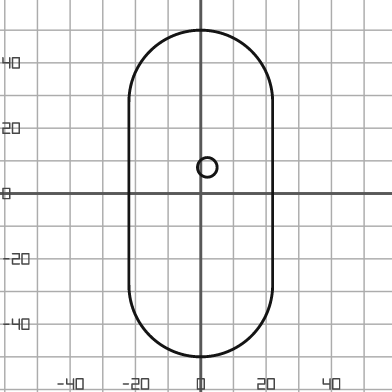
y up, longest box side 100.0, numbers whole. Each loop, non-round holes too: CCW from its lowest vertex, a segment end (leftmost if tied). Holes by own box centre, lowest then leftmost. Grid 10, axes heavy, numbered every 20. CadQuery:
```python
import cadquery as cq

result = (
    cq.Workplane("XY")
    .moveTo(-22.0, -28.0)
    .threePointArc((0.0, -50.0), (22.0, -28.0))
    .lineTo(22.0, 28.0)
    .threePointArc((0.0, 50.0), (-22.0, 28.0))
    .close()
    .moveTo(2.0, 8.0)
    .circle(3.0)
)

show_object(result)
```